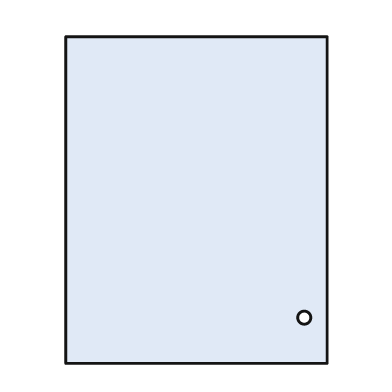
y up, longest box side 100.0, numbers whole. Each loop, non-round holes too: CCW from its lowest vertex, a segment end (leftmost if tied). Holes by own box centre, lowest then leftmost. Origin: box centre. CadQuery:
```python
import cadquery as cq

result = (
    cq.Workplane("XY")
    .moveTo(-40.0, -50.0)
    .lineTo(40.0, -50.0)
    .lineTo(40.0, 50.0)
    .lineTo(-40.0, 50.0)
    .close()
    .moveTo(33.0, -36.0)
    .circle(2.0)
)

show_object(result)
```